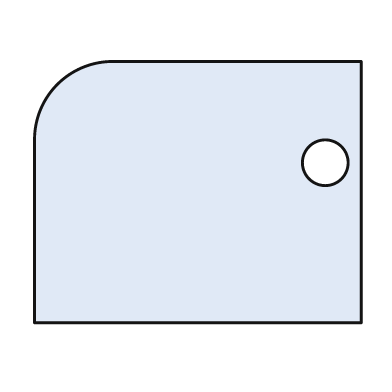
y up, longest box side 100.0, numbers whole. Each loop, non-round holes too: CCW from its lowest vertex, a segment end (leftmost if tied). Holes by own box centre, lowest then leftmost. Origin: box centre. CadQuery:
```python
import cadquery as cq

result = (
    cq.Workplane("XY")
    .moveTo(-50.0, -40.0)
    .lineTo(50.0, -40.0)
    .lineTo(50.0, 40.0)
    .lineTo(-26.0, 40.0)
    .threePointArc((-43.0, 33.0), (-50.0, 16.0))
    .close()
    .moveTo(39.0, 9.0)
    .circle(7.0)
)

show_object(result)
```